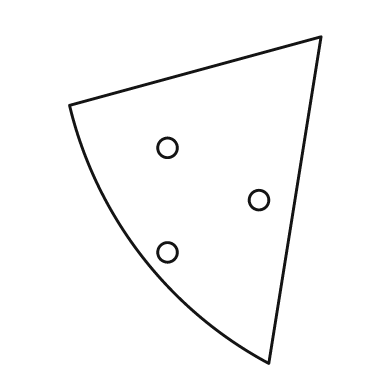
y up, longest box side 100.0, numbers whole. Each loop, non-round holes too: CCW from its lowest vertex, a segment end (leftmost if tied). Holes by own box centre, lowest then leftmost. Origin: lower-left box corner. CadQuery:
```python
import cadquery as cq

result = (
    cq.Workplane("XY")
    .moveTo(61.0, 0.0)
    .lineTo(77.0, 100.0)
    .lineTo(0.0, 79.0)
    .threePointArc((22.0, 33.0), (61.0, 0.0))
    .close()
    .moveTo(30.0, 34.0)
    .circle(3.0)
    .moveTo(58.0, 50.0)
    .circle(3.0)
    .moveTo(30.0, 66.0)
    .circle(3.0)
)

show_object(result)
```